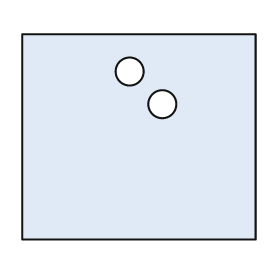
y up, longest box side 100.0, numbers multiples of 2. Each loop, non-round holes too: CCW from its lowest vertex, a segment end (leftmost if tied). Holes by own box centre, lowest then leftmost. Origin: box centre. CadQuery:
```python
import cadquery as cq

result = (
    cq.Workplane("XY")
    .moveTo(-50.0, -44.0)
    .lineTo(50.0, -44.0)
    .lineTo(50.0, 44.0)
    .lineTo(-50.0, 44.0)
    .close()
    .moveTo(10.0, 14.0)
    .circle(6.0)
    .moveTo(-4.0, 28.0)
    .circle(6.0)
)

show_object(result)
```